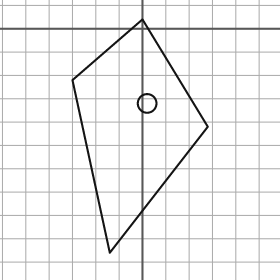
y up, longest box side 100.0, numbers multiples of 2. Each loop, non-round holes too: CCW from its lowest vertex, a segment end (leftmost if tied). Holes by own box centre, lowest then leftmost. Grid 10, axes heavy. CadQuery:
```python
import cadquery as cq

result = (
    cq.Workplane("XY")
    .moveTo(-14.0, -96.0)
    .lineTo(28.0, -42.0)
    .lineTo(0.0, 4.0)
    .lineTo(-30.0, -22.0)
    .close()
    .moveTo(2.0, -32.0)
    .circle(4.0)
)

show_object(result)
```